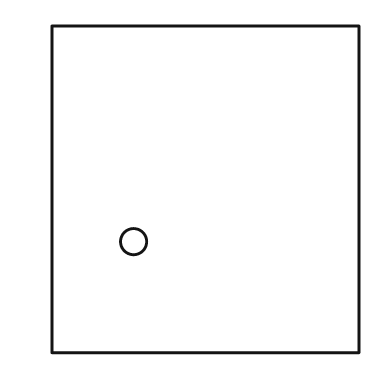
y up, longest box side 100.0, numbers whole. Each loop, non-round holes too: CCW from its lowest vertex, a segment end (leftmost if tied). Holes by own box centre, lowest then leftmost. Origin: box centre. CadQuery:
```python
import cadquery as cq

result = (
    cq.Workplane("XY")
    .moveTo(-47.0, -50.0)
    .lineTo(47.0, -50.0)
    .lineTo(47.0, 50.0)
    .lineTo(-47.0, 50.0)
    .close()
    .moveTo(-22.0, -16.0)
    .circle(4.0)
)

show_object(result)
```